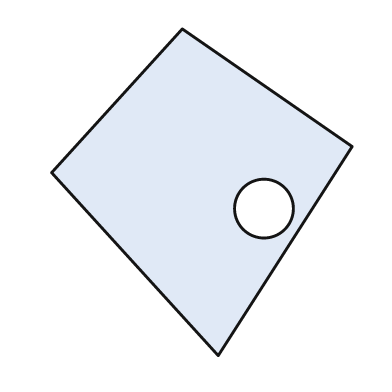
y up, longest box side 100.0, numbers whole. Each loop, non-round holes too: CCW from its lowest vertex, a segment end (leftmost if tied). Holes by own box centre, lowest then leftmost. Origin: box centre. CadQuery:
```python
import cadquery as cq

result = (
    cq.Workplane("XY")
    .moveTo(5.0, -50.0)
    .lineTo(46.0, 14.0)
    .lineTo(-6.0, 50.0)
    .lineTo(-46.0, 6.0)
    .close()
    .moveTo(19.0, -5.0)
    .circle(9.0)
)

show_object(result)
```